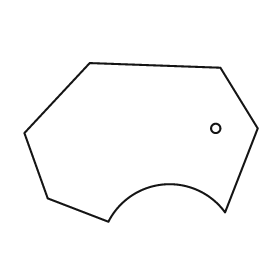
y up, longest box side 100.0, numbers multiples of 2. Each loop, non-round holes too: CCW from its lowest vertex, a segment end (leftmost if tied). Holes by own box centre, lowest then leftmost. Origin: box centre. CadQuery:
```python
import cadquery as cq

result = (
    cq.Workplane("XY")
    .moveTo(-14.0, -34.0)
    .threePointArc((10.0, -18.0), (36.0, -30.0))
    .lineTo(50.0, 6.0)
    .lineTo(34.0, 32.0)
    .lineTo(-22.0, 34.0)
    .lineTo(-50.0, 4.0)
    .lineTo(-40.0, -24.0)
    .close()
    .moveTo(32.0, 6.0)
    .circle(2.0)
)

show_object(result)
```